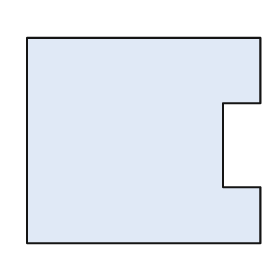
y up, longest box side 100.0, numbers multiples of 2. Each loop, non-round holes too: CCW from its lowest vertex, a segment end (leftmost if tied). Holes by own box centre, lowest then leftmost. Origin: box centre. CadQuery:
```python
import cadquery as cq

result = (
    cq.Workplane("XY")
    .moveTo(-50.0, -44.0)
    .lineTo(50.0, -44.0)
    .lineTo(50.0, -20.0)
    .lineTo(34.0, -20.0)
    .lineTo(34.0, 16.0)
    .lineTo(50.0, 16.0)
    .lineTo(50.0, 44.0)
    .lineTo(-50.0, 44.0)
    .close()
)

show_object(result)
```